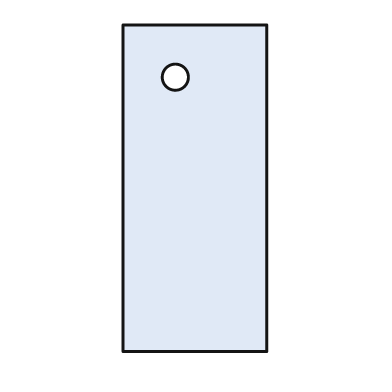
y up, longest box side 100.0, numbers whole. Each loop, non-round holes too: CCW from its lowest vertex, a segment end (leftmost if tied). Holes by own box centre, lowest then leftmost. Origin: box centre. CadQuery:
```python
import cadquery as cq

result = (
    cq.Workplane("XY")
    .moveTo(-22.0, -50.0)
    .lineTo(22.0, -50.0)
    .lineTo(22.0, 50.0)
    .lineTo(-22.0, 50.0)
    .close()
    .moveTo(-6.0, 34.0)
    .circle(4.0)
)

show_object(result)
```